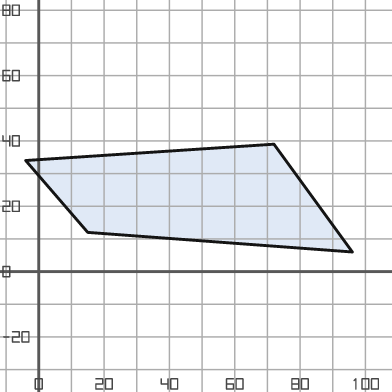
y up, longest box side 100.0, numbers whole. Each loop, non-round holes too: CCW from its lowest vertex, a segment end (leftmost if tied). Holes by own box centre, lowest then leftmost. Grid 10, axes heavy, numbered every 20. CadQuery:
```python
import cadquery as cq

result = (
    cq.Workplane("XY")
    .moveTo(96.0, 6.0)
    .lineTo(72.0, 39.0)
    .lineTo(-4.0, 34.0)
    .lineTo(15.0, 12.0)
    .close()
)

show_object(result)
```